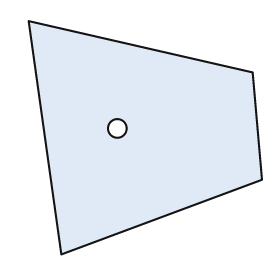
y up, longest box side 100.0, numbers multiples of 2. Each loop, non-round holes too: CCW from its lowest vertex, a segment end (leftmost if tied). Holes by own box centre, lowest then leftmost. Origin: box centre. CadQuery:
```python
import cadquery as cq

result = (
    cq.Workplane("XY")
    .moveTo(-36.0, -50.0)
    .lineTo(50.0, -18.0)
    .lineTo(46.0, 28.0)
    .lineTo(-50.0, 50.0)
    .close()
    .moveTo(-12.0, 4.0)
    .circle(4.0)
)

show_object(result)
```